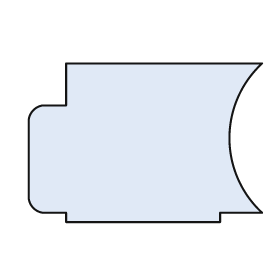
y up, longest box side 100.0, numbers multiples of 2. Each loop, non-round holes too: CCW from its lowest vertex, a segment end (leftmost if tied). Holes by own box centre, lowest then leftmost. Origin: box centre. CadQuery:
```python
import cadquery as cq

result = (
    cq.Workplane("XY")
    .moveTo(-34.0, -34.0)
    .lineTo(32.0, -34.0)
    .lineTo(32.0, -30.0)
    .lineTo(50.0, -30.0)
    .threePointArc((36.0, 2.0), (50.0, 34.0))
    .lineTo(-34.0, 34.0)
    .lineTo(-34.0, 16.0)
    .lineTo(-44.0, 16.0)
    .threePointArc((-48.0, 14.0), (-50.0, 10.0))
    .lineTo(-50.0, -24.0)
    .threePointArc((-48.0, -28.0), (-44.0, -30.0))
    .lineTo(-34.0, -30.0)
    .close()
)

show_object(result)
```